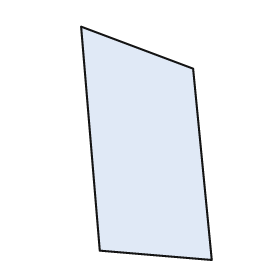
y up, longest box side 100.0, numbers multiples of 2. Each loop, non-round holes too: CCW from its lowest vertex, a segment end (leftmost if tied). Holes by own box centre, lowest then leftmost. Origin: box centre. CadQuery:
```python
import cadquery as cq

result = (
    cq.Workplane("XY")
    .moveTo(28.0, -50.0)
    .lineTo(20.0, 32.0)
    .lineTo(-28.0, 50.0)
    .lineTo(-20.0, -46.0)
    .close()
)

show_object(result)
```